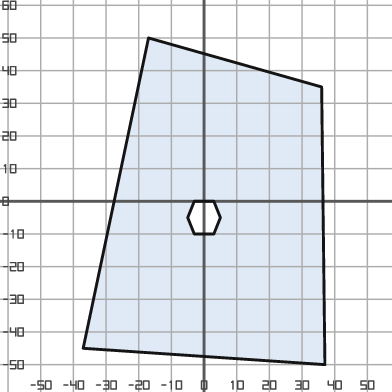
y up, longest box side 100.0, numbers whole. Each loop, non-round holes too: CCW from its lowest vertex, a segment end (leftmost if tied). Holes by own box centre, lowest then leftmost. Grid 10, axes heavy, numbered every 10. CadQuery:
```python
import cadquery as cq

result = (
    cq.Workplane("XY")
    .moveTo(37.0, -50.0)
    .lineTo(36.0, 35.0)
    .lineTo(-17.0, 50.0)
    .lineTo(-37.0, -45.0)
    .close()
    .moveTo(-3.0, -10.0)
    .lineTo(3.0, -10.0)
    .lineTo(5.0, -5.0)
    .lineTo(3.0, 0.0)
    .lineTo(-3.0, 0.0)
    .lineTo(-5.0, -5.0)
    .close()
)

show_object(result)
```